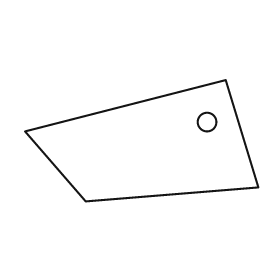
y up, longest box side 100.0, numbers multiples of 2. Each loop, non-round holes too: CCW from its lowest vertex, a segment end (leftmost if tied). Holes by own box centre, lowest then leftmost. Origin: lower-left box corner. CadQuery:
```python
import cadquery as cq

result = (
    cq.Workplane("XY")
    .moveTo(26.0, 0.0)
    .lineTo(100.0, 6.0)
    .lineTo(86.0, 52.0)
    .lineTo(0.0, 30.0)
    .close()
    .moveTo(78.0, 34.0)
    .circle(4.0)
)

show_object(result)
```